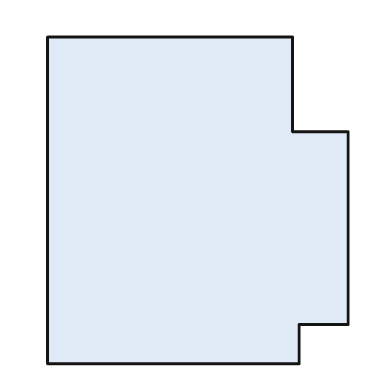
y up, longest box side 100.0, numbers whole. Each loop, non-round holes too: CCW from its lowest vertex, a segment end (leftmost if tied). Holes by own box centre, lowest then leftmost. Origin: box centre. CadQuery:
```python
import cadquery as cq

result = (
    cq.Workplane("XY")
    .moveTo(-46.0, -50.0)
    .lineTo(31.0, -50.0)
    .lineTo(31.0, -38.0)
    .lineTo(46.0, -38.0)
    .lineTo(46.0, 21.0)
    .lineTo(29.0, 21.0)
    .lineTo(29.0, 50.0)
    .lineTo(-46.0, 50.0)
    .close()
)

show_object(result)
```